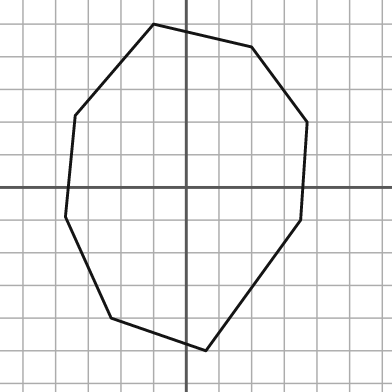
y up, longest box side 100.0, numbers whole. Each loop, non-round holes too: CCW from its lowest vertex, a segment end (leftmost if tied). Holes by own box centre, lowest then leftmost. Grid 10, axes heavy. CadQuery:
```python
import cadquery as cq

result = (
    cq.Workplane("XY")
    .moveTo(6.0, -50.0)
    .lineTo(35.0, -10.0)
    .lineTo(37.0, 20.0)
    .lineTo(20.0, 43.0)
    .lineTo(-10.0, 50.0)
    .lineTo(-34.0, 22.0)
    .lineTo(-37.0, -9.0)
    .lineTo(-23.0, -40.0)
    .close()
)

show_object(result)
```